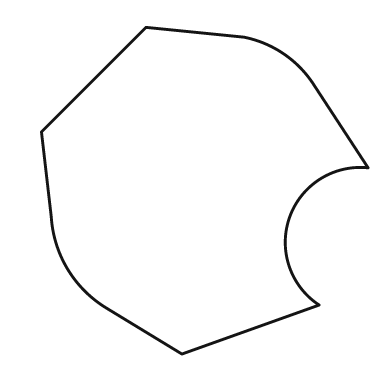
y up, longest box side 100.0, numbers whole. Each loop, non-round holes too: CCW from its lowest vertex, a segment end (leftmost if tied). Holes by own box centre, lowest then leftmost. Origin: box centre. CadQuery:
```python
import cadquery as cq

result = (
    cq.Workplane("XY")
    .moveTo(-7.0, -50.0)
    .lineTo(35.0, -35.0)
    .threePointArc((26.0, -8.0), (50.0, 7.0))
    .lineTo(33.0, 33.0)
    .threePointArc((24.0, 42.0), (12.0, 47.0))
    .lineTo(-18.0, 50.0)
    .lineTo(-50.0, 18.0)
    .lineTo(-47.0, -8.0)
    .threePointArc((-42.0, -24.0), (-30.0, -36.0))
    .close()
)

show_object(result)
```